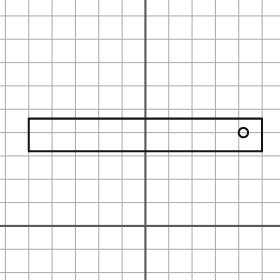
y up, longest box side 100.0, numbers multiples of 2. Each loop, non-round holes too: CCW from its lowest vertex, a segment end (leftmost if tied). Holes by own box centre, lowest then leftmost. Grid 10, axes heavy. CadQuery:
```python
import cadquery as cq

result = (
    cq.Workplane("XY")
    .moveTo(-50.0, 32.0)
    .lineTo(50.0, 32.0)
    .lineTo(50.0, 46.0)
    .lineTo(-50.0, 46.0)
    .close()
    .moveTo(42.0, 40.0)
    .circle(2.0)
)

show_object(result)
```